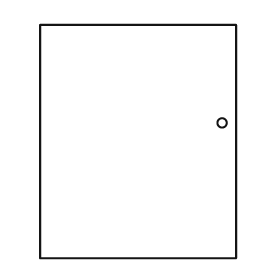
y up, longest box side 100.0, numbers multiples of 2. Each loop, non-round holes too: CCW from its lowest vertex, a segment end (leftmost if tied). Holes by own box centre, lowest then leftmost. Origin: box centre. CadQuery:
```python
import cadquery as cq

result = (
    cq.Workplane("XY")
    .moveTo(-42.0, -50.0)
    .lineTo(42.0, -50.0)
    .lineTo(42.0, 50.0)
    .lineTo(-42.0, 50.0)
    .close()
    .moveTo(36.0, 8.0)
    .circle(2.0)
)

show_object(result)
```